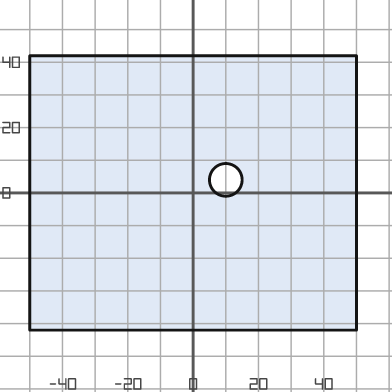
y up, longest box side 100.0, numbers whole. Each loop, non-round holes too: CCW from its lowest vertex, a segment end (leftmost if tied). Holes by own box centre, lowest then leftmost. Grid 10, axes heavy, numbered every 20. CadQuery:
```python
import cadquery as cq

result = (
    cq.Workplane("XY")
    .moveTo(-50.0, -42.0)
    .lineTo(50.0, -42.0)
    .lineTo(50.0, 42.0)
    .lineTo(-50.0, 42.0)
    .close()
    .moveTo(10.0, 4.0)
    .circle(5.0)
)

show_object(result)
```